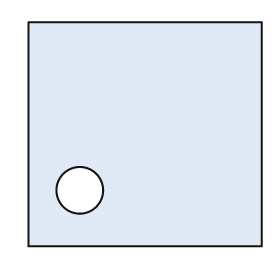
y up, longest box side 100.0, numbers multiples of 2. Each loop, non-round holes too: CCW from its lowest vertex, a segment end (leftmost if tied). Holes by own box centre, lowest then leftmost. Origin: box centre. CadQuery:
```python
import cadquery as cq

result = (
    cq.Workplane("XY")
    .moveTo(-50.0, -48.0)
    .lineTo(50.0, -48.0)
    .lineTo(50.0, 48.0)
    .lineTo(-50.0, 48.0)
    .close()
    .moveTo(-28.0, -24.0)
    .circle(10.0)
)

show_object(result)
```